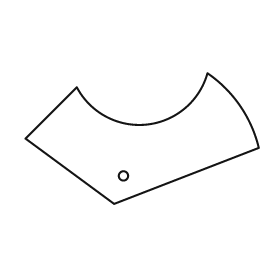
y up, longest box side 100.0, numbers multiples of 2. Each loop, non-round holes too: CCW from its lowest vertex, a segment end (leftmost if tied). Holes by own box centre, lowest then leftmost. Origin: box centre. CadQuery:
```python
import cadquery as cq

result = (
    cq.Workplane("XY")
    .moveTo(-12.0, -28.0)
    .lineTo(50.0, -4.0)
    .threePointArc((42.0, 14.0), (28.0, 28.0))
    .threePointArc((2.0, 6.0), (-28.0, 22.0))
    .lineTo(-50.0, 0.0)
    .close()
    .moveTo(-8.0, -16.0)
    .circle(2.0)
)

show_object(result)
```